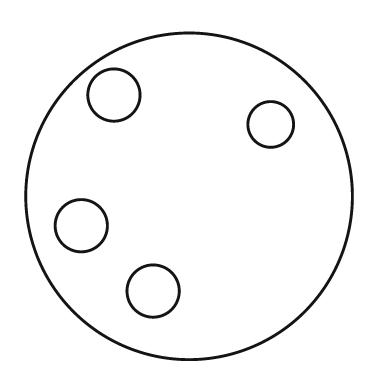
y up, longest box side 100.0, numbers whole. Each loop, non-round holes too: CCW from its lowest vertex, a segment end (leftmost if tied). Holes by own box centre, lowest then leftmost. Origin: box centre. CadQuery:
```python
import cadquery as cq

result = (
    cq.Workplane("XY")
    .moveTo(0.0, 0.0)
    .circle(50.0)
    .moveTo(-11.0, -29.0)
    .circle(8.0)
    .moveTo(-33.0, -9.0)
    .circle(8.0)
    .moveTo(25.0, 22.0)
    .circle(7.0)
    .moveTo(-23.0, 31.0)
    .circle(8.0)
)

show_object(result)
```